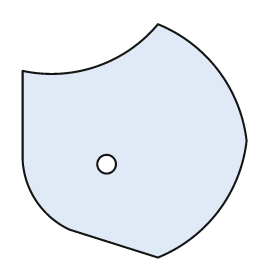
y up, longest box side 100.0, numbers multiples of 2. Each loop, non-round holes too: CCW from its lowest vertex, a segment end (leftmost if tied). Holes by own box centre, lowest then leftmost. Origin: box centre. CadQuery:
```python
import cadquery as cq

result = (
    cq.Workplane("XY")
    .moveTo(10.0, -50.0)
    .threePointArc((36.0, -30.0), (48.0, 0.0))
    .threePointArc((36.0, 30.0), (10.0, 50.0))
    .threePointArc((-16.0, 32.0), (-48.0, 30.0))
    .lineTo(-48.0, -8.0)
    .threePointArc((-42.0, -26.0), (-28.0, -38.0))
    .close()
    .moveTo(-12.0, -10.0)
    .circle(4.0)
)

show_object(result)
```